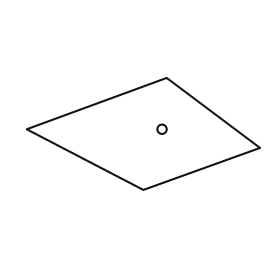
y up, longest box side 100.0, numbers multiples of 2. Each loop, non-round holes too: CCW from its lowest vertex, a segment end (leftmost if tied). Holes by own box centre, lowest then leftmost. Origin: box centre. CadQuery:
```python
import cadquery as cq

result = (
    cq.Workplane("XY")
    .moveTo(0.0, -24.0)
    .lineTo(50.0, -6.0)
    .lineTo(10.0, 24.0)
    .lineTo(-50.0, 2.0)
    .close()
    .moveTo(8.0, 2.0)
    .circle(2.0)
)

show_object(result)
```